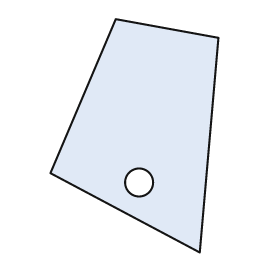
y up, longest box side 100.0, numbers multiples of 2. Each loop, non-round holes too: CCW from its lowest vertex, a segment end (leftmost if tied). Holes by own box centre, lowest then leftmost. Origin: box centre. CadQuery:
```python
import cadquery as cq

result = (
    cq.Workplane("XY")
    .moveTo(28.0, -50.0)
    .lineTo(36.0, 42.0)
    .lineTo(-8.0, 50.0)
    .lineTo(-36.0, -16.0)
    .close()
    .moveTo(2.0, -20.0)
    .circle(6.0)
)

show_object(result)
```